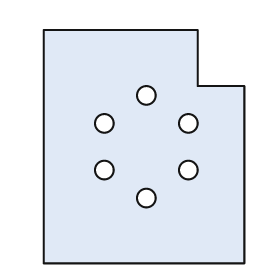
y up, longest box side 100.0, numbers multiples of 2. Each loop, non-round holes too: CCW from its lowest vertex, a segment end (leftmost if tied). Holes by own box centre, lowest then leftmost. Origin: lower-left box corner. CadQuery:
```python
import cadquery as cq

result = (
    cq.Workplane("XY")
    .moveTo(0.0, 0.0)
    .lineTo(86.0, 0.0)
    .lineTo(86.0, 76.0)
    .lineTo(66.0, 76.0)
    .lineTo(66.0, 100.0)
    .lineTo(0.0, 100.0)
    .close()
    .moveTo(44.0, 28.0)
    .circle(4.0)
    .moveTo(26.0, 40.0)
    .circle(4.0)
    .moveTo(62.0, 40.0)
    .circle(4.0)
    .moveTo(26.0, 60.0)
    .circle(4.0)
    .moveTo(62.0, 60.0)
    .circle(4.0)
    .moveTo(44.0, 72.0)
    .circle(4.0)
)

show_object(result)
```